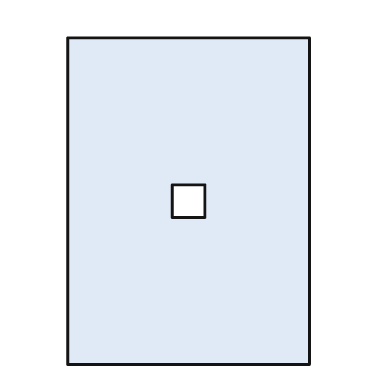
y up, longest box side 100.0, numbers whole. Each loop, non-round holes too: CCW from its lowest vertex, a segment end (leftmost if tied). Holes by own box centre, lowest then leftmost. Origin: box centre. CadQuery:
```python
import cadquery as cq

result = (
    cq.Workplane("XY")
    .moveTo(-37.0, -50.0)
    .lineTo(37.0, -50.0)
    .lineTo(37.0, 50.0)
    .lineTo(-37.0, 50.0)
    .close()
    .moveTo(-5.0, -5.0)
    .lineTo(5.0, -5.0)
    .lineTo(5.0, 5.0)
    .lineTo(-5.0, 5.0)
    .close()
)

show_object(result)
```